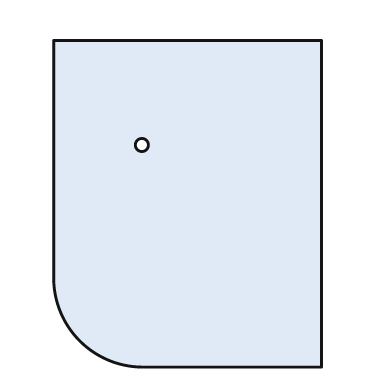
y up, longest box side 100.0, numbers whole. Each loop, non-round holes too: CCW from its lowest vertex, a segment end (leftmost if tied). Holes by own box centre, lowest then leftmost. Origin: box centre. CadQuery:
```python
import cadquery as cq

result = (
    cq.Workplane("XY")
    .moveTo(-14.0, -50.0)
    .lineTo(41.0, -50.0)
    .lineTo(41.0, 50.0)
    .lineTo(-41.0, 50.0)
    .lineTo(-41.0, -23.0)
    .threePointArc((-33.0, -42.0), (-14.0, -50.0))
    .close()
    .moveTo(-14.0, 18.0)
    .circle(2.0)
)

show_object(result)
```